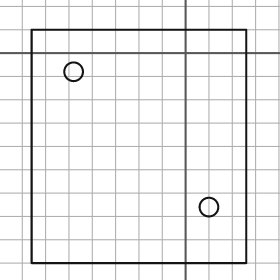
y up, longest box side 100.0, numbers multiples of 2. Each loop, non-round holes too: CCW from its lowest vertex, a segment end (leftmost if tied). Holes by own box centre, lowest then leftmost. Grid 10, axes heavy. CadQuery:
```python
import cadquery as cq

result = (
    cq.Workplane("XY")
    .moveTo(-66.0, -90.0)
    .lineTo(26.0, -90.0)
    .lineTo(26.0, 10.0)
    .lineTo(-66.0, 10.0)
    .close()
    .moveTo(10.0, -66.0)
    .circle(4.0)
    .moveTo(-48.0, -8.0)
    .circle(4.0)
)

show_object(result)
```